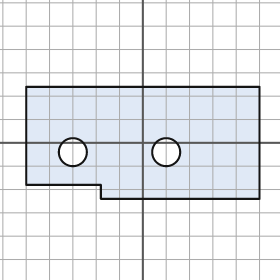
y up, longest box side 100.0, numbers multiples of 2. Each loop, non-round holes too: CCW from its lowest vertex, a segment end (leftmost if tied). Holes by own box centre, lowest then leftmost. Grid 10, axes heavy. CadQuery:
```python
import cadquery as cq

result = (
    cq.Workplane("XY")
    .moveTo(-18.0, -24.0)
    .lineTo(50.0, -24.0)
    .lineTo(50.0, 24.0)
    .lineTo(-50.0, 24.0)
    .lineTo(-50.0, -18.0)
    .lineTo(-18.0, -18.0)
    .close()
    .moveTo(-30.0, -4.0)
    .circle(6.0)
    .moveTo(10.0, -4.0)
    .circle(6.0)
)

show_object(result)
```